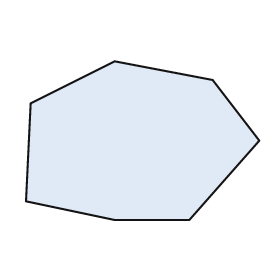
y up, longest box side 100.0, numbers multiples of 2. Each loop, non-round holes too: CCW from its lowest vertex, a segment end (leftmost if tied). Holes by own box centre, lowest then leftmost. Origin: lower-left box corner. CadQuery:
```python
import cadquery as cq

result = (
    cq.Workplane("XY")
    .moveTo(38.0, 0.0)
    .lineTo(70.0, 0.0)
    .lineTo(100.0, 34.0)
    .lineTo(80.0, 60.0)
    .lineTo(38.0, 68.0)
    .lineTo(2.0, 50.0)
    .lineTo(0.0, 8.0)
    .close()
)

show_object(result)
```